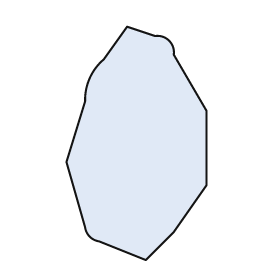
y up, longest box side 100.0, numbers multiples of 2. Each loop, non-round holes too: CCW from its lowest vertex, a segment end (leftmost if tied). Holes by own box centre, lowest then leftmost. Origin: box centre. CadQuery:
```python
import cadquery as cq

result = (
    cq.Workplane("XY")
    .moveTo(4.0, -50.0)
    .lineTo(16.0, -38.0)
    .lineTo(30.0, -18.0)
    .lineTo(30.0, 14.0)
    .lineTo(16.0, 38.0)
    .threePointArc((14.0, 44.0), (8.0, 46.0))
    .lineTo(-4.0, 50.0)
    .lineTo(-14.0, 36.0)
    .threePointArc((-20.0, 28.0), (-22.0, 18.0))
    .lineTo(-30.0, -8.0)
    .lineTo(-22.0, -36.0)
    .threePointArc((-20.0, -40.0), (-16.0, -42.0))
    .close()
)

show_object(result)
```